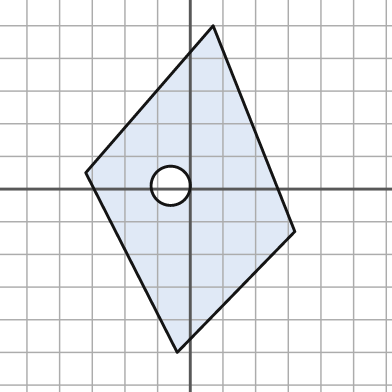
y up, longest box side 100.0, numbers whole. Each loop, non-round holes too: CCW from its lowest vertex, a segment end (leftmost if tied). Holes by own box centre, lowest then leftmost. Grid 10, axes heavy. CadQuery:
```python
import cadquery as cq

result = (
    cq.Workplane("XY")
    .moveTo(-4.0, -50.0)
    .lineTo(32.0, -13.0)
    .lineTo(7.0, 50.0)
    .lineTo(-32.0, 5.0)
    .close()
    .moveTo(-6.0, 1.0)
    .circle(6.0)
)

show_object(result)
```